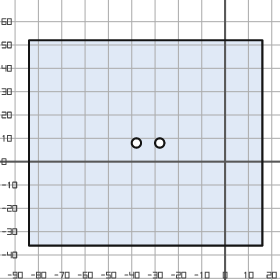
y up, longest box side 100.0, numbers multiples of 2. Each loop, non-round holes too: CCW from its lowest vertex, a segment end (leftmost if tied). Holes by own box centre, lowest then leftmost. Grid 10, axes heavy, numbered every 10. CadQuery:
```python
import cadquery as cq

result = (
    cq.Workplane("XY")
    .moveTo(-84.0, -36.0)
    .lineTo(16.0, -36.0)
    .lineTo(16.0, 52.0)
    .lineTo(-84.0, 52.0)
    .close()
    .moveTo(-38.0, 8.0)
    .circle(2.0)
    .moveTo(-28.0, 8.0)
    .circle(2.0)
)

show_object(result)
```